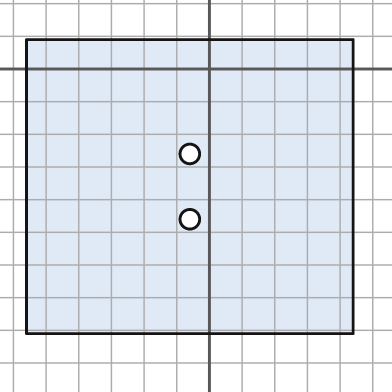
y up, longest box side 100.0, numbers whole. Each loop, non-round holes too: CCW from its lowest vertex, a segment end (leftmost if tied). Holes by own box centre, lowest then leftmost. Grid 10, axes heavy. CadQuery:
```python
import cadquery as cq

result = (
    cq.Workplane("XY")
    .moveTo(-56.0, -81.0)
    .lineTo(44.0, -81.0)
    .lineTo(44.0, 9.0)
    .lineTo(-56.0, 9.0)
    .close()
    .moveTo(-6.0, -46.0)
    .circle(3.0)
    .moveTo(-6.0, -26.0)
    .circle(3.0)
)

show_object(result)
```